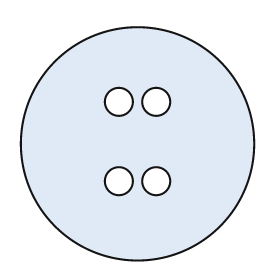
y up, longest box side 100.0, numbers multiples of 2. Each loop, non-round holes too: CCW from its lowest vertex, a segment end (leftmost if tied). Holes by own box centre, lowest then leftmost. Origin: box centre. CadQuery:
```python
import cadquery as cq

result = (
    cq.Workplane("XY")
    .moveTo(0.0, 0.0)
    .circle(50.0)
    .moveTo(-8.0, -16.0)
    .circle(6.0)
    .moveTo(8.0, -16.0)
    .circle(6.0)
    .moveTo(-8.0, 18.0)
    .circle(6.0)
    .moveTo(8.0, 18.0)
    .circle(6.0)
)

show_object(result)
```